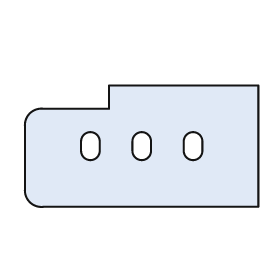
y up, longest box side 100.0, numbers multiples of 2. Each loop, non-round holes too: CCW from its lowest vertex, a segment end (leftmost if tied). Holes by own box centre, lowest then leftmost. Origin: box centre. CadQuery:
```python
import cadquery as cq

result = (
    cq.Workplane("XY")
    .moveTo(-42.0, -26.0)
    .lineTo(50.0, -26.0)
    .lineTo(50.0, 26.0)
    .lineTo(-14.0, 26.0)
    .lineTo(-14.0, 16.0)
    .lineTo(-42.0, 16.0)
    .threePointArc((-48.0, 14.0), (-50.0, 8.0))
    .lineTo(-50.0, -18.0)
    .threePointArc((-48.0, -24.0), (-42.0, -26.0))
    .close()
    .moveTo(-26.0, -2.0)
    .threePointArc((-22.0, -6.0), (-18.0, -2.0))
    .lineTo(-18.0, 2.0)
    .threePointArc((-22.0, 6.0), (-26.0, 2.0))
    .close()
    .moveTo(-4.0, -2.0)
    .threePointArc((0.0, -6.0), (4.0, -2.0))
    .lineTo(4.0, 2.0)
    .threePointArc((0.0, 6.0), (-4.0, 2.0))
    .close()
    .moveTo(18.0, -2.0)
    .threePointArc((22.0, -6.0), (26.0, -2.0))
    .lineTo(26.0, 2.0)
    .threePointArc((22.0, 6.0), (18.0, 2.0))
    .close()
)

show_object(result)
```